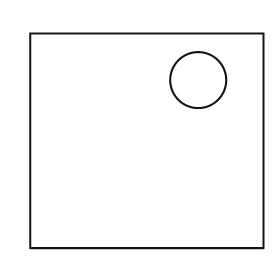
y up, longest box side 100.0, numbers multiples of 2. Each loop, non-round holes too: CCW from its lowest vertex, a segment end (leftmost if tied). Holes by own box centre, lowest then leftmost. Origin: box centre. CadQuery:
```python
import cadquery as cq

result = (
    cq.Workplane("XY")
    .moveTo(-50.0, -46.0)
    .lineTo(50.0, -46.0)
    .lineTo(50.0, 46.0)
    .lineTo(-50.0, 46.0)
    .close()
    .moveTo(22.0, 26.0)
    .circle(12.0)
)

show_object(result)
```